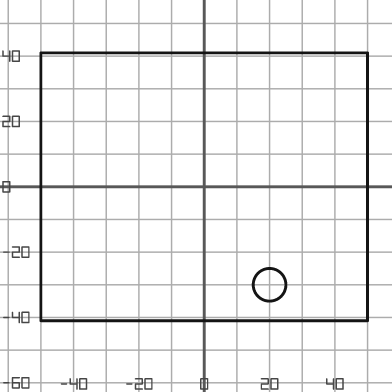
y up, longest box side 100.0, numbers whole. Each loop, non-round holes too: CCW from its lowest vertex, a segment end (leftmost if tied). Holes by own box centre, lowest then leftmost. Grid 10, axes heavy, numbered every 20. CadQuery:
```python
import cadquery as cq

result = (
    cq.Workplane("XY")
    .moveTo(-50.0, -41.0)
    .lineTo(50.0, -41.0)
    .lineTo(50.0, 41.0)
    .lineTo(-50.0, 41.0)
    .close()
    .moveTo(20.0, -30.0)
    .circle(5.0)
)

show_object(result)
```